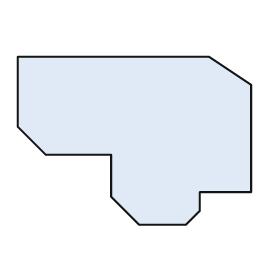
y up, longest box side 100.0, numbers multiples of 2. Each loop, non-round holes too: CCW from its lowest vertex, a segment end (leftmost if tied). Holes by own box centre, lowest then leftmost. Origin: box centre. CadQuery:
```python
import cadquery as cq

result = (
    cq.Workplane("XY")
    .moveTo(2.0, -36.0)
    .lineTo(22.0, -36.0)
    .lineTo(28.0, -30.0)
    .lineTo(28.0, -22.0)
    .lineTo(50.0, -22.0)
    .lineTo(50.0, 24.0)
    .lineTo(32.0, 36.0)
    .lineTo(-50.0, 36.0)
    .lineTo(-50.0, 6.0)
    .lineTo(-38.0, -6.0)
    .lineTo(-10.0, -6.0)
    .lineTo(-10.0, -24.0)
    .close()
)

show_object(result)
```